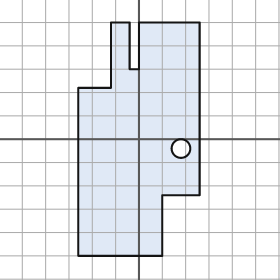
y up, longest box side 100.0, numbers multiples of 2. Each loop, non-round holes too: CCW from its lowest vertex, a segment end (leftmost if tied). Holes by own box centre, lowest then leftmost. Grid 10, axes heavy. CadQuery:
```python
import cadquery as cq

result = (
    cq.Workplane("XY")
    .moveTo(-26.0, -50.0)
    .lineTo(10.0, -50.0)
    .lineTo(10.0, -24.0)
    .lineTo(26.0, -24.0)
    .lineTo(26.0, 50.0)
    .lineTo(0.0, 50.0)
    .lineTo(0.0, 30.0)
    .lineTo(-4.0, 30.0)
    .lineTo(-4.0, 50.0)
    .lineTo(-12.0, 50.0)
    .lineTo(-12.0, 22.0)
    .lineTo(-26.0, 22.0)
    .close()
    .moveTo(18.0, -4.0)
    .circle(4.0)
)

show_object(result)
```